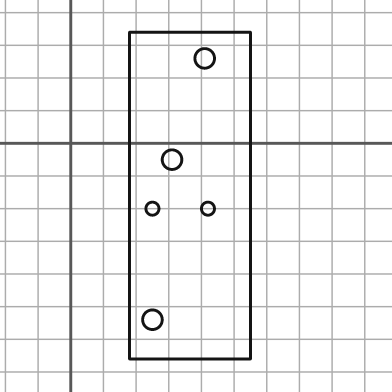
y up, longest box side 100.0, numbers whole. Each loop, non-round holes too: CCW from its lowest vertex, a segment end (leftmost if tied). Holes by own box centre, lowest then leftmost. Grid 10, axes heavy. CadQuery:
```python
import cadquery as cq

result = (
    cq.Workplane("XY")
    .moveTo(18.0, -66.0)
    .lineTo(55.0, -66.0)
    .lineTo(55.0, 34.0)
    .lineTo(18.0, 34.0)
    .close()
    .moveTo(25.0, -54.0)
    .circle(3.0)
    .moveTo(25.0, -20.0)
    .circle(2.0)
    .moveTo(42.0, -20.0)
    .circle(2.0)
    .moveTo(31.0, -5.0)
    .circle(3.0)
    .moveTo(41.0, 26.0)
    .circle(3.0)
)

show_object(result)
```